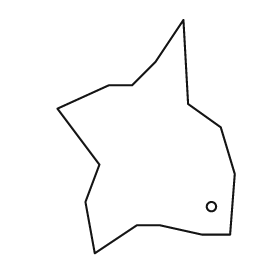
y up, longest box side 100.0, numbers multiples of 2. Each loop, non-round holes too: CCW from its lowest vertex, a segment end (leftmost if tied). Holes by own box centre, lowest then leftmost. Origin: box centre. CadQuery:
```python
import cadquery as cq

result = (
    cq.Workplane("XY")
    .moveTo(-22.0, -50.0)
    .lineTo(-4.0, -38.0)
    .lineTo(6.0, -38.0)
    .lineTo(24.0, -42.0)
    .lineTo(36.0, -42.0)
    .lineTo(38.0, -16.0)
    .lineTo(32.0, 4.0)
    .lineTo(18.0, 14.0)
    .lineTo(16.0, 50.0)
    .lineTo(4.0, 32.0)
    .lineTo(-6.0, 22.0)
    .lineTo(-16.0, 22.0)
    .lineTo(-38.0, 12.0)
    .lineTo(-20.0, -12.0)
    .lineTo(-26.0, -28.0)
    .close()
    .moveTo(28.0, -30.0)
    .circle(2.0)
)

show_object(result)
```